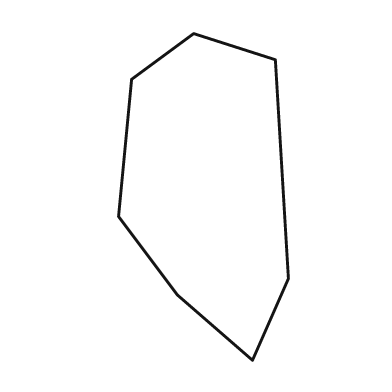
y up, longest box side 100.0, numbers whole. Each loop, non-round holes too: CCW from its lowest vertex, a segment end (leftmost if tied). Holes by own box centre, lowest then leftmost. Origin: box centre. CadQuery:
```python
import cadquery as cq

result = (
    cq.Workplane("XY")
    .moveTo(15.0, -50.0)
    .lineTo(26.0, -25.0)
    .lineTo(22.0, 42.0)
    .lineTo(-3.0, 50.0)
    .lineTo(-22.0, 36.0)
    .lineTo(-26.0, -6.0)
    .lineTo(-8.0, -30.0)
    .close()
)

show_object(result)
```